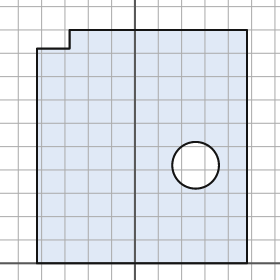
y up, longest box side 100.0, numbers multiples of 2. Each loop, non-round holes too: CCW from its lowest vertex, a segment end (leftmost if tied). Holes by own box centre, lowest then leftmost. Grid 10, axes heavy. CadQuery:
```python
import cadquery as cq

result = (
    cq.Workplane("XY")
    .moveTo(-42.0, 0.0)
    .lineTo(48.0, 0.0)
    .lineTo(48.0, 100.0)
    .lineTo(-28.0, 100.0)
    .lineTo(-28.0, 92.0)
    .lineTo(-42.0, 92.0)
    .close()
    .moveTo(26.0, 42.0)
    .circle(10.0)
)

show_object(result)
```